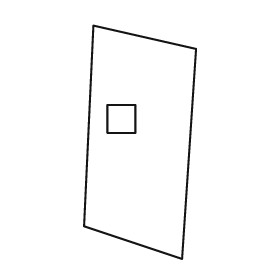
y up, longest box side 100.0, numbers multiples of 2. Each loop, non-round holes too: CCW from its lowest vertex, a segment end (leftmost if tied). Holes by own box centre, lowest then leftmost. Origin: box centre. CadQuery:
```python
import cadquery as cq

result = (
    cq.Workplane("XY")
    .moveTo(18.0, -50.0)
    .lineTo(24.0, 40.0)
    .lineTo(-20.0, 50.0)
    .lineTo(-24.0, -36.0)
    .close()
    .moveTo(-14.0, 4.0)
    .lineTo(-2.0, 4.0)
    .lineTo(-2.0, 16.0)
    .lineTo(-14.0, 16.0)
    .close()
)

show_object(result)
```